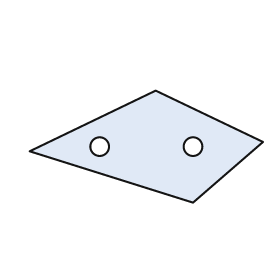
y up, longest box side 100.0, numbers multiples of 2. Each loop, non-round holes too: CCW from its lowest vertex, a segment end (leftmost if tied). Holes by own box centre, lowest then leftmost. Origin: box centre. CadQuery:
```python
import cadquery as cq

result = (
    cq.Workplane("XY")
    .moveTo(20.0, -24.0)
    .lineTo(50.0, 2.0)
    .lineTo(4.0, 24.0)
    .lineTo(-50.0, -2.0)
    .close()
    .moveTo(-20.0, 0.0)
    .circle(4.0)
    .moveTo(20.0, 0.0)
    .circle(4.0)
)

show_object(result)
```